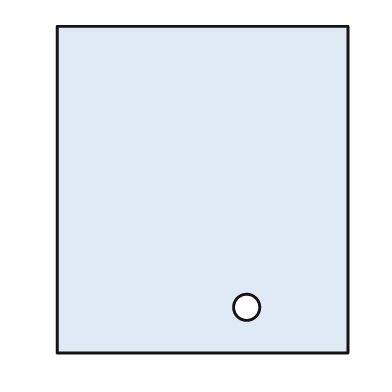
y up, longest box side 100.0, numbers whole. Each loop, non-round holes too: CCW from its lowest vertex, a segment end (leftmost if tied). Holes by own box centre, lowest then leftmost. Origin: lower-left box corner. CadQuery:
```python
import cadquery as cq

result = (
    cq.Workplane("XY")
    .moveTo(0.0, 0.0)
    .lineTo(89.0, 0.0)
    .lineTo(89.0, 100.0)
    .lineTo(0.0, 100.0)
    .close()
    .moveTo(58.0, 14.0)
    .circle(4.0)
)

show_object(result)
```